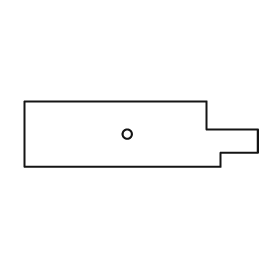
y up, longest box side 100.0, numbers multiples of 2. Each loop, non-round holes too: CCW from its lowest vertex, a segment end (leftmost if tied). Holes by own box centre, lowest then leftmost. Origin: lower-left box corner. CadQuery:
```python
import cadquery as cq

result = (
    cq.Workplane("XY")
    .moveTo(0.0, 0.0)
    .lineTo(84.0, 0.0)
    .lineTo(84.0, 6.0)
    .lineTo(100.0, 6.0)
    .lineTo(100.0, 16.0)
    .lineTo(78.0, 16.0)
    .lineTo(78.0, 28.0)
    .lineTo(0.0, 28.0)
    .close()
    .moveTo(44.0, 14.0)
    .circle(2.0)
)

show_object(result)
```